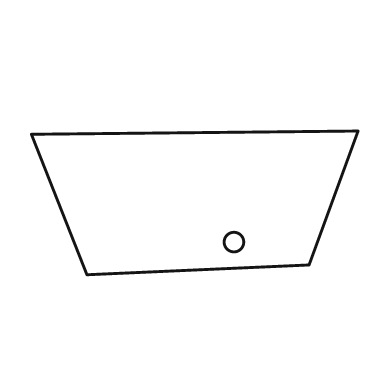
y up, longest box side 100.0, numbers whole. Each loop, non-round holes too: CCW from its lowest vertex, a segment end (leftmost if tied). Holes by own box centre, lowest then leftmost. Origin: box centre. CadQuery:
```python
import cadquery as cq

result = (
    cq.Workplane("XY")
    .moveTo(-33.0, -22.0)
    .lineTo(35.0, -19.0)
    .lineTo(50.0, 22.0)
    .lineTo(-50.0, 21.0)
    .close()
    .moveTo(12.0, -12.0)
    .circle(3.0)
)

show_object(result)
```